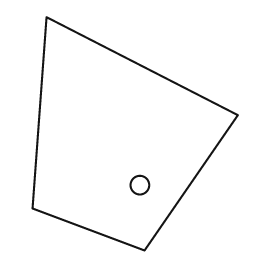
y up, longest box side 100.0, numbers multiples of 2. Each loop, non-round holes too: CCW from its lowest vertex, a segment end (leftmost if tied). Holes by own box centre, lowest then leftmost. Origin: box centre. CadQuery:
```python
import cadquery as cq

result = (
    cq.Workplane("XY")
    .moveTo(4.0, -50.0)
    .lineTo(44.0, 8.0)
    .lineTo(-38.0, 50.0)
    .lineTo(-44.0, -32.0)
    .close()
    .moveTo(2.0, -22.0)
    .circle(4.0)
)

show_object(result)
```